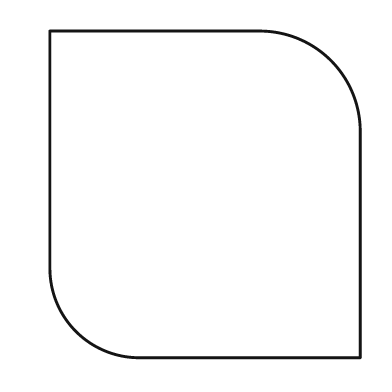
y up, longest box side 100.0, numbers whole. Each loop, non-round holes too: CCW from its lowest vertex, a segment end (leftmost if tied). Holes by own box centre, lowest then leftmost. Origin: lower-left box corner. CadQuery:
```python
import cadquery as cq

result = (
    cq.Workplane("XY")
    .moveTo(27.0, 0.0)
    .lineTo(95.0, 0.0)
    .lineTo(95.0, 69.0)
    .threePointArc((86.0, 91.0), (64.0, 100.0))
    .lineTo(0.0, 100.0)
    .lineTo(0.0, 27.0)
    .threePointArc((8.0, 8.0), (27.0, 0.0))
    .close()
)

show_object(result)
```